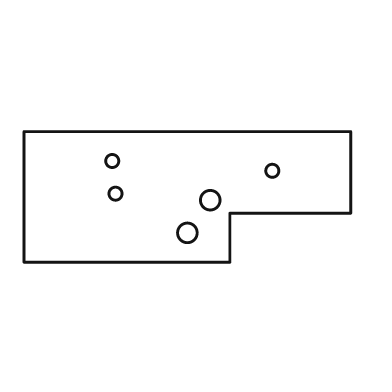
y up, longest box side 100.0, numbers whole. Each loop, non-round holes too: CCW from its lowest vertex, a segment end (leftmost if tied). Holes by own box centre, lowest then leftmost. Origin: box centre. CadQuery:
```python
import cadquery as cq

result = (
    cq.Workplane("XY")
    .moveTo(-50.0, -20.0)
    .lineTo(13.0, -20.0)
    .lineTo(13.0, -5.0)
    .lineTo(50.0, -5.0)
    .lineTo(50.0, 20.0)
    .lineTo(-50.0, 20.0)
    .close()
    .moveTo(0.0, -11.0)
    .circle(3.0)
    .moveTo(7.0, -1.0)
    .circle(3.0)
    .moveTo(-22.0, 1.0)
    .circle(2.0)
    .moveTo(26.0, 8.0)
    .circle(2.0)
    .moveTo(-23.0, 11.0)
    .circle(2.0)
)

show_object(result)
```